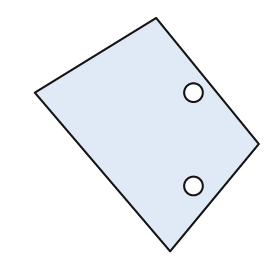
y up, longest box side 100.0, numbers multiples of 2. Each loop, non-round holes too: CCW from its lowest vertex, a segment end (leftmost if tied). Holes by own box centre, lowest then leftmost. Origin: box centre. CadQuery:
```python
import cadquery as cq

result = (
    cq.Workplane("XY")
    .moveTo(10.0, -50.0)
    .lineTo(48.0, -4.0)
    .lineTo(4.0, 50.0)
    .lineTo(-48.0, 18.0)
    .close()
    .moveTo(20.0, -22.0)
    .circle(4.0)
    .moveTo(20.0, 18.0)
    .circle(4.0)
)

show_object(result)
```